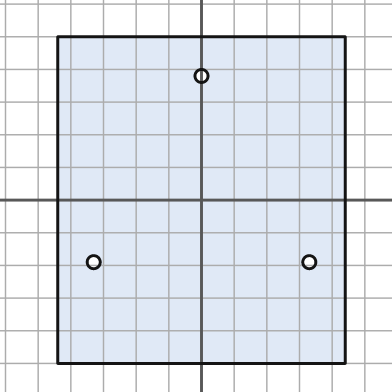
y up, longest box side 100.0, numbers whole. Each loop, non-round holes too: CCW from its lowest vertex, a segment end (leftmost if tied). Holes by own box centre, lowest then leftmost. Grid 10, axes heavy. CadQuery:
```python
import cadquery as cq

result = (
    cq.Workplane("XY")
    .moveTo(-44.0, -50.0)
    .lineTo(44.0, -50.0)
    .lineTo(44.0, 50.0)
    .lineTo(-44.0, 50.0)
    .close()
    .moveTo(-33.0, -19.0)
    .circle(2.0)
    .moveTo(33.0, -19.0)
    .circle(2.0)
    .moveTo(0.0, 38.0)
    .circle(2.0)
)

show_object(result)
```